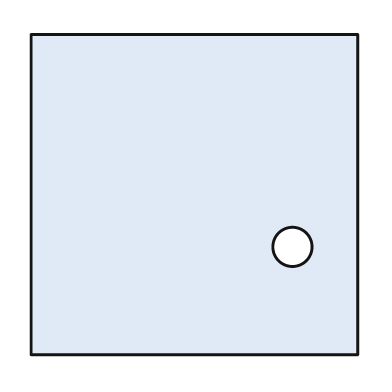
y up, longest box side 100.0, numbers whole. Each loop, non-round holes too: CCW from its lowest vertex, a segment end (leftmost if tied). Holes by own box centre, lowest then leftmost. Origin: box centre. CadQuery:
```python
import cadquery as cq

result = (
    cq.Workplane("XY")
    .moveTo(-50.0, -49.0)
    .lineTo(50.0, -49.0)
    .lineTo(50.0, 49.0)
    .lineTo(-50.0, 49.0)
    .close()
    .moveTo(30.0, -16.0)
    .circle(6.0)
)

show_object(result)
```